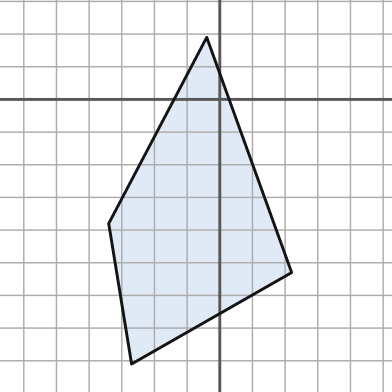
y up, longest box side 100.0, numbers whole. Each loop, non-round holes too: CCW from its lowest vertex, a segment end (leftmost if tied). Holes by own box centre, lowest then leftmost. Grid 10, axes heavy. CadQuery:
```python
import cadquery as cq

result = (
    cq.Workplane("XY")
    .moveTo(-27.0, -81.0)
    .lineTo(22.0, -53.0)
    .lineTo(-4.0, 19.0)
    .lineTo(-34.0, -38.0)
    .close()
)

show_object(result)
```